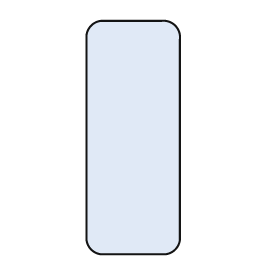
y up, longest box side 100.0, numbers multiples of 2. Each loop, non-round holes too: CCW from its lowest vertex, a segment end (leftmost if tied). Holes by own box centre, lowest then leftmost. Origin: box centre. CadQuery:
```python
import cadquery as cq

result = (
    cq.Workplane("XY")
    .moveTo(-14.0, -50.0)
    .lineTo(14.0, -50.0)
    .threePointArc((18.0, -48.0), (20.0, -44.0))
    .lineTo(20.0, 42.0)
    .threePointArc((18.0, 48.0), (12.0, 50.0))
    .lineTo(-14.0, 50.0)
    .threePointArc((-18.0, 48.0), (-20.0, 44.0))
    .lineTo(-20.0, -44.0)
    .threePointArc((-18.0, -48.0), (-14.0, -50.0))
    .close()
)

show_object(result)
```